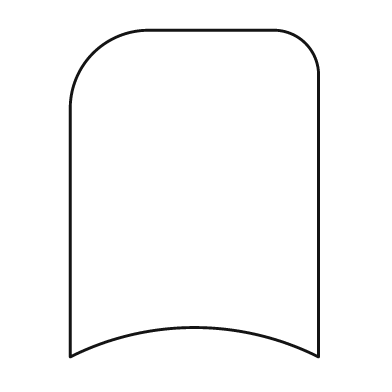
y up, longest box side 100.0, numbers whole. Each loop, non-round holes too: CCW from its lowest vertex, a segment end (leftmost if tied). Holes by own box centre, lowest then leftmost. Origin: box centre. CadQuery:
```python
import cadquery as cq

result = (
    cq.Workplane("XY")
    .moveTo(-38.0, -50.0)
    .threePointArc((0.0, -41.0), (38.0, -50.0))
    .lineTo(38.0, 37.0)
    .threePointArc((34.0, 46.0), (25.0, 50.0))
    .lineTo(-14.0, 50.0)
    .threePointArc((-31.0, 43.0), (-38.0, 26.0))
    .close()
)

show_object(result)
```